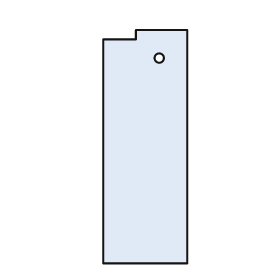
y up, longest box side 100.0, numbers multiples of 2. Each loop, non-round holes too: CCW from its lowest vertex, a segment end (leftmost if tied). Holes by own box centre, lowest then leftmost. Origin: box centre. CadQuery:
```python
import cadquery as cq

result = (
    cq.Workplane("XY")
    .moveTo(-18.0, -50.0)
    .lineTo(18.0, -50.0)
    .lineTo(18.0, 50.0)
    .lineTo(-4.0, 50.0)
    .lineTo(-4.0, 46.0)
    .lineTo(-18.0, 46.0)
    .close()
    .moveTo(6.0, 38.0)
    .circle(2.0)
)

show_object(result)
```